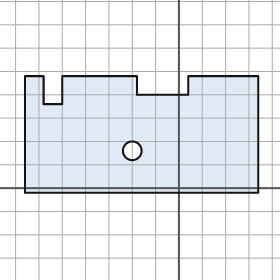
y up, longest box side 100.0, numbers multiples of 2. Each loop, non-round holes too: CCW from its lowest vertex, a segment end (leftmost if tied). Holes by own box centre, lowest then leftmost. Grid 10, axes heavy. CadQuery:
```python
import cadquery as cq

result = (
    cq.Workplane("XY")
    .moveTo(-66.0, -2.0)
    .lineTo(34.0, -2.0)
    .lineTo(34.0, 48.0)
    .lineTo(4.0, 48.0)
    .lineTo(4.0, 40.0)
    .lineTo(-18.0, 40.0)
    .lineTo(-18.0, 48.0)
    .lineTo(-50.0, 48.0)
    .lineTo(-50.0, 36.0)
    .lineTo(-58.0, 36.0)
    .lineTo(-58.0, 48.0)
    .lineTo(-66.0, 48.0)
    .close()
    .moveTo(-20.0, 16.0)
    .circle(4.0)
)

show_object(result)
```